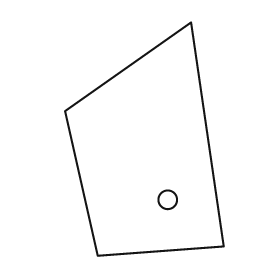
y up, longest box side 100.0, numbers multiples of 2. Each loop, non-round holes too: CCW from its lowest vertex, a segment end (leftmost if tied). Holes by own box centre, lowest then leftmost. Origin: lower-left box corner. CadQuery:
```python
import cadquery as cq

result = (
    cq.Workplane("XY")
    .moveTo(14.0, 0.0)
    .lineTo(68.0, 4.0)
    .lineTo(54.0, 100.0)
    .lineTo(0.0, 62.0)
    .close()
    .moveTo(44.0, 24.0)
    .circle(4.0)
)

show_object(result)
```